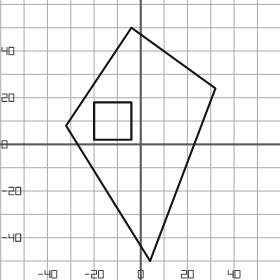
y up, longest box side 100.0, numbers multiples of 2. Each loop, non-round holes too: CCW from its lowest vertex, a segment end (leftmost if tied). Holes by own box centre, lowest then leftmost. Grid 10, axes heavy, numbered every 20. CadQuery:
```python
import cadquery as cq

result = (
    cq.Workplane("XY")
    .moveTo(4.0, -50.0)
    .lineTo(32.0, 24.0)
    .lineTo(-4.0, 50.0)
    .lineTo(-32.0, 8.0)
    .close()
    .moveTo(-20.0, 2.0)
    .lineTo(-4.0, 2.0)
    .lineTo(-4.0, 18.0)
    .lineTo(-20.0, 18.0)
    .close()
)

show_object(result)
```